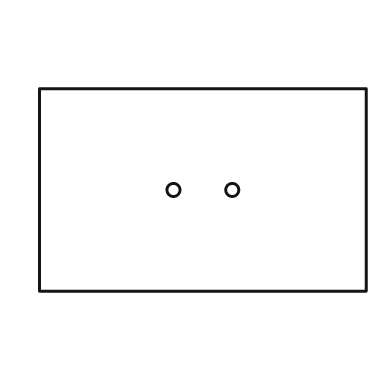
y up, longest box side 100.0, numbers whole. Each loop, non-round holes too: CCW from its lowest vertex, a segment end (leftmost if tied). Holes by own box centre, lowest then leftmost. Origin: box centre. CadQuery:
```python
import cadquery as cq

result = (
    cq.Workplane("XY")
    .moveTo(-50.0, -31.0)
    .lineTo(50.0, -31.0)
    .lineTo(50.0, 31.0)
    .lineTo(-50.0, 31.0)
    .close()
    .moveTo(-9.0, 0.0)
    .circle(2.0)
    .moveTo(9.0, 0.0)
    .circle(2.0)
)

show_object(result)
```